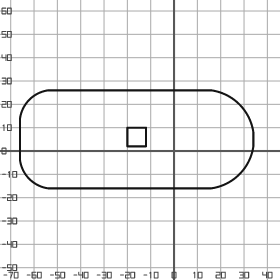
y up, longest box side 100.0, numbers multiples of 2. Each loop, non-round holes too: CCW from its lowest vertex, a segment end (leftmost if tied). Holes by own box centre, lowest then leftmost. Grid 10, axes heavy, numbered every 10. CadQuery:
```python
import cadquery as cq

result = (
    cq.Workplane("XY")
    .moveTo(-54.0, -16.0)
    .lineTo(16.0, -16.0)
    .threePointArc((28.0, -10.0), (34.0, 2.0))
    .lineTo(34.0, 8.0)
    .threePointArc((28.0, 20.0), (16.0, 26.0))
    .lineTo(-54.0, 26.0)
    .threePointArc((-62.0, 22.0), (-66.0, 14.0))
    .lineTo(-66.0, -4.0)
    .threePointArc((-62.0, -12.0), (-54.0, -16.0))
    .close()
    .moveTo(-20.0, 2.0)
    .lineTo(-12.0, 2.0)
    .lineTo(-12.0, 10.0)
    .lineTo(-20.0, 10.0)
    .close()
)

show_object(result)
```